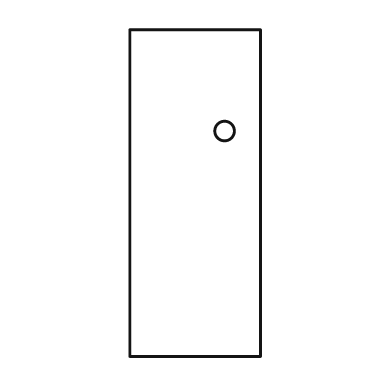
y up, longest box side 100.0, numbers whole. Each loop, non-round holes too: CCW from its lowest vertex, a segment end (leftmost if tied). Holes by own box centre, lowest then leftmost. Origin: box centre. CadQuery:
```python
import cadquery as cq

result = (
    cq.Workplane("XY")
    .moveTo(-20.0, -50.0)
    .lineTo(20.0, -50.0)
    .lineTo(20.0, 50.0)
    .lineTo(-20.0, 50.0)
    .close()
    .moveTo(9.0, 19.0)
    .circle(3.0)
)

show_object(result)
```